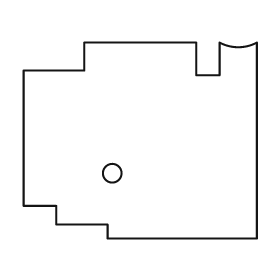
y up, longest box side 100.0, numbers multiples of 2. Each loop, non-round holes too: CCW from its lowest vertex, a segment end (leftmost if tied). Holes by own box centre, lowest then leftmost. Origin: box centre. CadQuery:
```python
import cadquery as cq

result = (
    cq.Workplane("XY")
    .moveTo(-14.0, -42.0)
    .lineTo(50.0, -42.0)
    .lineTo(50.0, 42.0)
    .threePointArc((42.0, 40.0), (34.0, 42.0))
    .lineTo(34.0, 28.0)
    .lineTo(24.0, 28.0)
    .lineTo(24.0, 42.0)
    .lineTo(-24.0, 42.0)
    .lineTo(-24.0, 30.0)
    .lineTo(-50.0, 30.0)
    .lineTo(-50.0, -28.0)
    .lineTo(-36.0, -28.0)
    .lineTo(-36.0, -36.0)
    .lineTo(-14.0, -36.0)
    .close()
    .moveTo(-12.0, -14.0)
    .circle(4.0)
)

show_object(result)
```